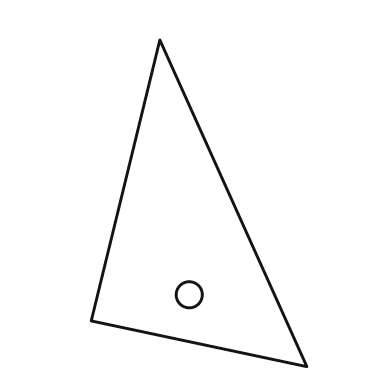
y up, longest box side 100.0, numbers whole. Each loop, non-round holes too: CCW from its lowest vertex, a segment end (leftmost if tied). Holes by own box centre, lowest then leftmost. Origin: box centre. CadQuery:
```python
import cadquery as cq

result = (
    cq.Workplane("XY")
    .moveTo(33.0, -50.0)
    .lineTo(-12.0, 50.0)
    .lineTo(-33.0, -36.0)
    .close()
    .moveTo(-3.0, -28.0)
    .circle(4.0)
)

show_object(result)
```